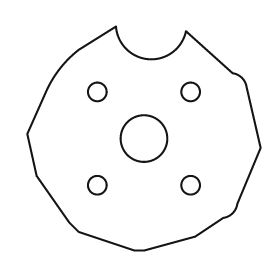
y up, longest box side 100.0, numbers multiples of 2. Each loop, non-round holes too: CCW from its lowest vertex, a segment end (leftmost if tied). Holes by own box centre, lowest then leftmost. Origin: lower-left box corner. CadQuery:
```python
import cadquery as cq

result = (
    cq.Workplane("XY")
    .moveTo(46.0, 0.0)
    .lineTo(50.0, 0.0)
    .lineTo(72.0, 6.0)
    .lineTo(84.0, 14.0)
    .threePointArc((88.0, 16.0), (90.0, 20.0))
    .lineTo(100.0, 44.0)
    .lineTo(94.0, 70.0)
    .threePointArc((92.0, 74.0), (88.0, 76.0))
    .lineTo(68.0, 94.0)
    .threePointArc((52.0, 82.0), (38.0, 96.0))
    .lineTo(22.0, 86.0)
    .threePointArc((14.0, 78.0), (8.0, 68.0))
    .lineTo(0.0, 50.0)
    .lineTo(4.0, 32.0)
    .lineTo(18.0, 12.0)
    .lineTo(22.0, 8.0)
    .close()
    .moveTo(30.0, 28.0)
    .circle(4.0)
    .moveTo(70.0, 28.0)
    .circle(4.0)
    .moveTo(50.0, 48.0)
    .circle(10.0)
    .moveTo(30.0, 68.0)
    .circle(4.0)
    .moveTo(70.0, 68.0)
    .circle(4.0)
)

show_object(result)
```